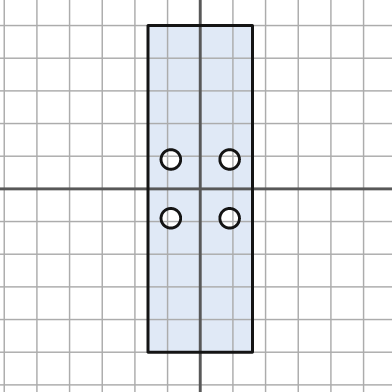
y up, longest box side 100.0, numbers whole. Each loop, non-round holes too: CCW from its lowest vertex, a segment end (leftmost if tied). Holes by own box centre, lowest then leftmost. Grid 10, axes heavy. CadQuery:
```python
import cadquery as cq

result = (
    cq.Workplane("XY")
    .moveTo(-16.0, -50.0)
    .lineTo(16.0, -50.0)
    .lineTo(16.0, 50.0)
    .lineTo(-16.0, 50.0)
    .close()
    .moveTo(-9.0, -9.0)
    .circle(3.0)
    .moveTo(9.0, -9.0)
    .circle(3.0)
    .moveTo(-9.0, 9.0)
    .circle(3.0)
    .moveTo(9.0, 9.0)
    .circle(3.0)
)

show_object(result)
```